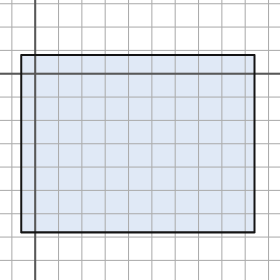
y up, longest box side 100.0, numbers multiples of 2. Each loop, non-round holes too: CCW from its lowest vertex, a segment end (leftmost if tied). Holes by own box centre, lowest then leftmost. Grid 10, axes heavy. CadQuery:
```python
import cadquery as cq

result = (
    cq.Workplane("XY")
    .moveTo(-6.0, -68.0)
    .lineTo(94.0, -68.0)
    .lineTo(94.0, 8.0)
    .lineTo(-6.0, 8.0)
    .close()
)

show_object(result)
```